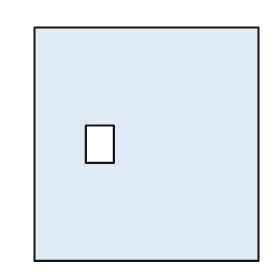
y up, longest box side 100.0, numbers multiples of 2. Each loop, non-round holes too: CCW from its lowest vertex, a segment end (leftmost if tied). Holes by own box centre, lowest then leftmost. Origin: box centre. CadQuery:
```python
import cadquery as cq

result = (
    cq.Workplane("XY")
    .moveTo(-48.0, -50.0)
    .lineTo(48.0, -50.0)
    .lineTo(48.0, 50.0)
    .lineTo(-48.0, 50.0)
    .close()
    .moveTo(-26.0, -8.0)
    .lineTo(-14.0, -8.0)
    .lineTo(-14.0, 8.0)
    .lineTo(-26.0, 8.0)
    .close()
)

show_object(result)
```